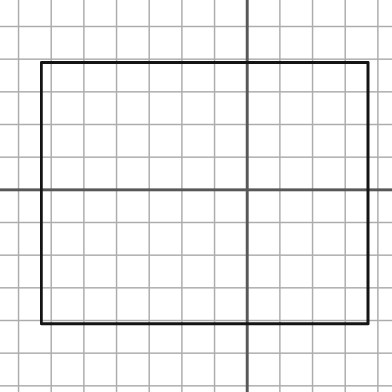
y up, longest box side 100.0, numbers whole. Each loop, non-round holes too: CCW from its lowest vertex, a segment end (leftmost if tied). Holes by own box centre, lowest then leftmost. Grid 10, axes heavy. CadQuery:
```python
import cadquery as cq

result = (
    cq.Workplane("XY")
    .moveTo(-63.0, -41.0)
    .lineTo(37.0, -41.0)
    .lineTo(37.0, 39.0)
    .lineTo(-63.0, 39.0)
    .close()
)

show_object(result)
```